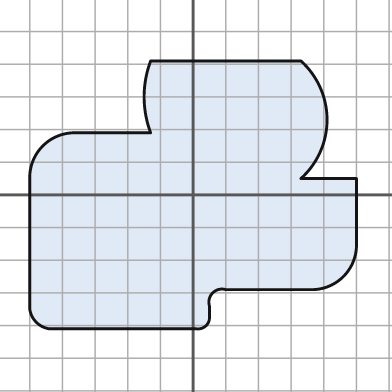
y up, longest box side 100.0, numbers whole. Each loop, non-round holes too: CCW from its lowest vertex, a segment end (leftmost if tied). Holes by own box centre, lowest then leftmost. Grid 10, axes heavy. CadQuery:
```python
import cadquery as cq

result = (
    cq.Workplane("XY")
    .moveTo(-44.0, -41.0)
    .lineTo(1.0, -41.0)
    .threePointArc((4.0, -40.0), (5.0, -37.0))
    .lineTo(5.0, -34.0)
    .threePointArc((6.0, -30.0), (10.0, -29.0))
    .lineTo(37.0, -29.0)
    .threePointArc((46.0, -25.0), (50.0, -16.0))
    .lineTo(50.0, 5.0)
    .lineTo(33.0, 5.0)
    .threePointArc((41.0, 23.0), (33.0, 41.0))
    .lineTo(-13.0, 41.0)
    .threePointArc((-15.0, 30.0), (-13.0, 19.0))
    .lineTo(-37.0, 19.0)
    .threePointArc((-46.0, 15.0), (-50.0, 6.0))
    .lineTo(-50.0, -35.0)
    .threePointArc((-48.0, -39.0), (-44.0, -41.0))
    .close()
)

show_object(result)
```